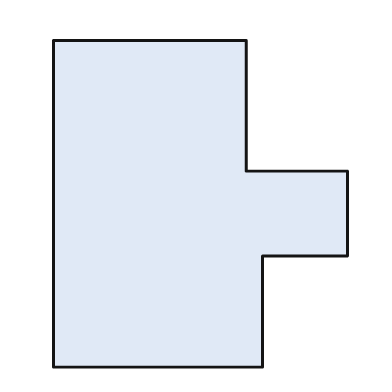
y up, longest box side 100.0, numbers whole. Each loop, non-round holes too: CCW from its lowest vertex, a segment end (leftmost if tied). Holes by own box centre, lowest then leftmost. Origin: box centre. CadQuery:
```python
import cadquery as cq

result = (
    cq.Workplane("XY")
    .moveTo(-45.0, -50.0)
    .lineTo(19.0, -50.0)
    .lineTo(19.0, -16.0)
    .lineTo(45.0, -16.0)
    .lineTo(45.0, 10.0)
    .lineTo(14.0, 10.0)
    .lineTo(14.0, 50.0)
    .lineTo(-45.0, 50.0)
    .close()
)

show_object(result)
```